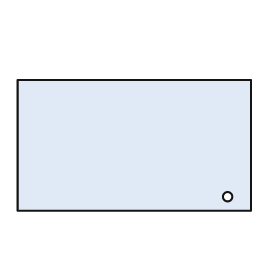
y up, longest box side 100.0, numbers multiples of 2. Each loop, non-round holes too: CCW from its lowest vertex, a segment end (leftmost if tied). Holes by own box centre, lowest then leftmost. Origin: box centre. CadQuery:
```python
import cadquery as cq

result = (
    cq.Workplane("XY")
    .moveTo(-50.0, -28.0)
    .lineTo(50.0, -28.0)
    .lineTo(50.0, 28.0)
    .lineTo(-50.0, 28.0)
    .close()
    .moveTo(40.0, -22.0)
    .circle(2.0)
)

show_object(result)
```